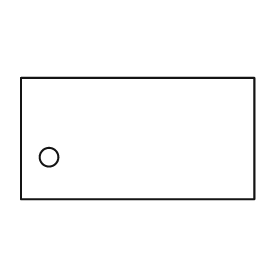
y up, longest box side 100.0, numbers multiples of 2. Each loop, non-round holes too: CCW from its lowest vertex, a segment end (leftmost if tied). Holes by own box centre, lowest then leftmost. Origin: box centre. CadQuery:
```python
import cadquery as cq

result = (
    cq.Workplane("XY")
    .moveTo(-50.0, -26.0)
    .lineTo(50.0, -26.0)
    .lineTo(50.0, 26.0)
    .lineTo(-50.0, 26.0)
    .close()
    .moveTo(-38.0, -8.0)
    .circle(4.0)
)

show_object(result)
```